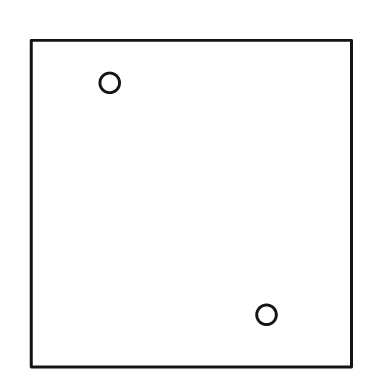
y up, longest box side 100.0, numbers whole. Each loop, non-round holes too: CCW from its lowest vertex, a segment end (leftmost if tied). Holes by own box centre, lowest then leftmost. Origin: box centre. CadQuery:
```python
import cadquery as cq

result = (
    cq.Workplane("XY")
    .moveTo(-49.0, -50.0)
    .lineTo(49.0, -50.0)
    .lineTo(49.0, 50.0)
    .lineTo(-49.0, 50.0)
    .close()
    .moveTo(23.0, -34.0)
    .circle(3.0)
    .moveTo(-25.0, 37.0)
    .circle(3.0)
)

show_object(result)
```